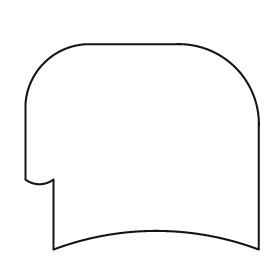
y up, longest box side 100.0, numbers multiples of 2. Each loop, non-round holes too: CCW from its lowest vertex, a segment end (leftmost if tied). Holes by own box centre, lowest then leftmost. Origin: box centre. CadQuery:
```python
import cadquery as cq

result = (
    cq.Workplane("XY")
    .moveTo(-38.0, -44.0)
    .threePointArc((6.0, -36.0), (50.0, -44.0))
    .lineTo(50.0, 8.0)
    .threePointArc((40.0, 34.0), (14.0, 44.0))
    .lineTo(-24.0, 44.0)
    .threePointArc((-42.0, 36.0), (-50.0, 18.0))
    .lineTo(-50.0, -14.0)
    .threePointArc((-44.0, -16.0), (-38.0, -14.0))
    .close()
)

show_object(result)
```